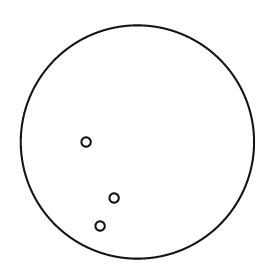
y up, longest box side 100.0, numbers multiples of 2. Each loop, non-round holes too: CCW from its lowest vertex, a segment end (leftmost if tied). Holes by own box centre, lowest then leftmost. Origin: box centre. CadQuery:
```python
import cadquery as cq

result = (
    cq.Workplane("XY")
    .moveTo(0.0, 0.0)
    .circle(50.0)
    .moveTo(-16.0, -36.0)
    .circle(2.0)
    .moveTo(-10.0, -24.0)
    .circle(2.0)
    .moveTo(-22.0, 0.0)
    .circle(2.0)
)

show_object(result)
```